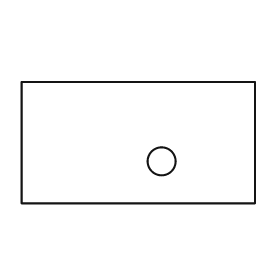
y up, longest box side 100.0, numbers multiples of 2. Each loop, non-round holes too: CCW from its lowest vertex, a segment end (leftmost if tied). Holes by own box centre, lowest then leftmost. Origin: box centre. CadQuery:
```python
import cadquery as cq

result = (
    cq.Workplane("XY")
    .moveTo(-50.0, -26.0)
    .lineTo(50.0, -26.0)
    .lineTo(50.0, 26.0)
    .lineTo(-50.0, 26.0)
    .close()
    .moveTo(10.0, -8.0)
    .circle(6.0)
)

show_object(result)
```